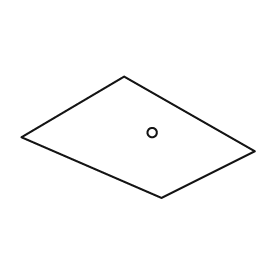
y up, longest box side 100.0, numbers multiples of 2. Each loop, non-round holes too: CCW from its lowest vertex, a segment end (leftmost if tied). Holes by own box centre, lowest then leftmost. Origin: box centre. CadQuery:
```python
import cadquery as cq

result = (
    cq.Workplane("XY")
    .moveTo(10.0, -26.0)
    .lineTo(50.0, -6.0)
    .lineTo(-6.0, 26.0)
    .lineTo(-50.0, 0.0)
    .close()
    .moveTo(6.0, 2.0)
    .circle(2.0)
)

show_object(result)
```